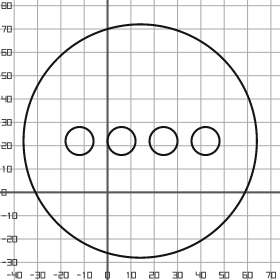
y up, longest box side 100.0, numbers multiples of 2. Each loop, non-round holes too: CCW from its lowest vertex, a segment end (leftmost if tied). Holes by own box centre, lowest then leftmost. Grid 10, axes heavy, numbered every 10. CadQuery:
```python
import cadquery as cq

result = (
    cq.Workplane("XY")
    .moveTo(14.0, 22.0)
    .circle(50.0)
    .moveTo(-12.0, 22.0)
    .circle(6.0)
    .moveTo(6.0, 22.0)
    .circle(6.0)
    .moveTo(24.0, 22.0)
    .circle(6.0)
    .moveTo(42.0, 22.0)
    .circle(6.0)
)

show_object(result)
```